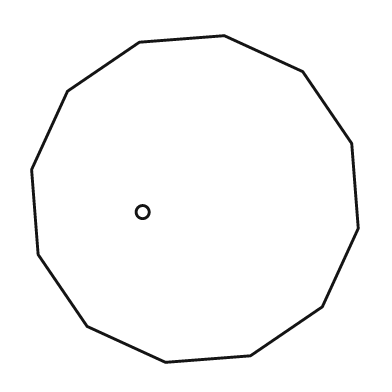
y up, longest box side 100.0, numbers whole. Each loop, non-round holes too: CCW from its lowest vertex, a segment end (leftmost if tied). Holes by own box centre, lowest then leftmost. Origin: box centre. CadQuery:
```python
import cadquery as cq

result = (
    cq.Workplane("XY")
    .moveTo(-9.0, -50.0)
    .lineTo(17.0, -48.0)
    .lineTo(39.0, -33.0)
    .lineTo(50.0, -9.0)
    .lineTo(48.0, 17.0)
    .lineTo(33.0, 39.0)
    .lineTo(9.0, 50.0)
    .lineTo(-17.0, 48.0)
    .lineTo(-39.0, 33.0)
    .lineTo(-50.0, 9.0)
    .lineTo(-48.0, -17.0)
    .lineTo(-33.0, -39.0)
    .close()
    .moveTo(-16.0, -4.0)
    .circle(2.0)
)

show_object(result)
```